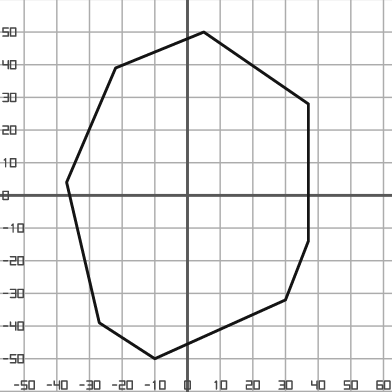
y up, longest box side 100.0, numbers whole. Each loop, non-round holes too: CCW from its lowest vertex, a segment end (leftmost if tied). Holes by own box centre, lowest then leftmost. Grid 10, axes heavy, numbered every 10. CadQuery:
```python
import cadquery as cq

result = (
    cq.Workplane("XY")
    .moveTo(-10.0, -50.0)
    .lineTo(30.0, -32.0)
    .lineTo(37.0, -14.0)
    .lineTo(37.0, 28.0)
    .lineTo(5.0, 50.0)
    .lineTo(-22.0, 39.0)
    .lineTo(-37.0, 4.0)
    .lineTo(-27.0, -39.0)
    .close()
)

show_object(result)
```